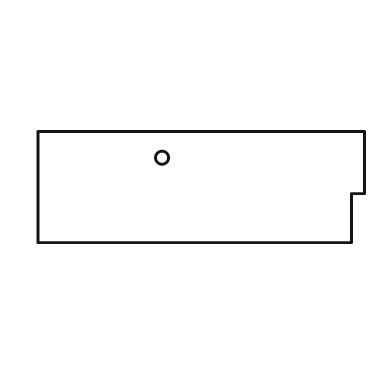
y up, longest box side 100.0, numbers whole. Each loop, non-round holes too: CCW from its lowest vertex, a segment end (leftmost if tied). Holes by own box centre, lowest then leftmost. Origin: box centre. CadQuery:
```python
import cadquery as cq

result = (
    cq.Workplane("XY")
    .moveTo(-50.0, -17.0)
    .lineTo(46.0, -17.0)
    .lineTo(46.0, -2.0)
    .lineTo(50.0, -2.0)
    .lineTo(50.0, 17.0)
    .lineTo(-50.0, 17.0)
    .close()
    .moveTo(-12.0, 9.0)
    .circle(2.0)
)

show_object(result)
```